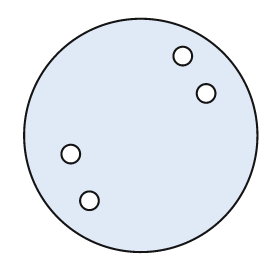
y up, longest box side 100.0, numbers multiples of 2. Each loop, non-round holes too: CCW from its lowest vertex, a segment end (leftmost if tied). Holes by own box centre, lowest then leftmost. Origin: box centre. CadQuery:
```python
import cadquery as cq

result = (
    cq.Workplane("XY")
    .moveTo(0.0, 0.0)
    .circle(50.0)
    .moveTo(-22.0, -28.0)
    .circle(4.0)
    .moveTo(-30.0, -8.0)
    .circle(4.0)
    .moveTo(28.0, 18.0)
    .circle(4.0)
    .moveTo(18.0, 34.0)
    .circle(4.0)
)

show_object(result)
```